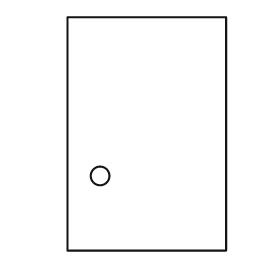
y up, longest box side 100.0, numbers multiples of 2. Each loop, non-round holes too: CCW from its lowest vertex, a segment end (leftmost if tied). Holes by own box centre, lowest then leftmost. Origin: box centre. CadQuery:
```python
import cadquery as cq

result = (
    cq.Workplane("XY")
    .moveTo(-34.0, -50.0)
    .lineTo(34.0, -50.0)
    .lineTo(34.0, 50.0)
    .lineTo(-34.0, 50.0)
    .close()
    .moveTo(-20.0, -18.0)
    .circle(4.0)
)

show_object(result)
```